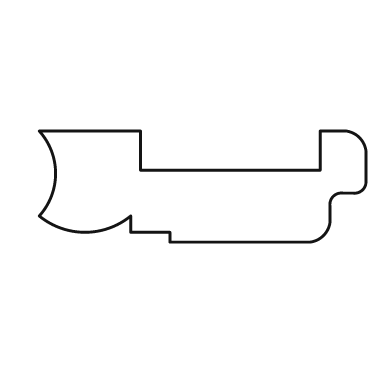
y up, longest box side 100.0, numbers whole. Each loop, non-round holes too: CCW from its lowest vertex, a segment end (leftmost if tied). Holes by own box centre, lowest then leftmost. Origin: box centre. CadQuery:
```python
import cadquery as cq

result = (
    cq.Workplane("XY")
    .moveTo(-10.0, -17.0)
    .lineTo(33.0, -17.0)
    .threePointArc((37.0, -15.0), (39.0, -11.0))
    .lineTo(39.0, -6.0)
    .threePointArc((40.0, -3.0), (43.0, -2.0))
    .lineTo(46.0, -2.0)
    .threePointArc((49.0, -1.0), (50.0, 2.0))
    .lineTo(50.0, 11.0)
    .threePointArc((48.0, 15.0), (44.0, 17.0))
    .lineTo(36.0, 17.0)
    .lineTo(36.0, 5.0)
    .lineTo(-19.0, 5.0)
    .lineTo(-19.0, 17.0)
    .lineTo(-50.0, 17.0)
    .threePointArc((-45.0, 4.0), (-50.0, -9.0))
    .threePointArc((-36.0, -14.0), (-22.0, -9.0))
    .lineTo(-22.0, -14.0)
    .lineTo(-10.0, -14.0)
    .close()
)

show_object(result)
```